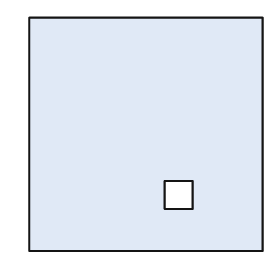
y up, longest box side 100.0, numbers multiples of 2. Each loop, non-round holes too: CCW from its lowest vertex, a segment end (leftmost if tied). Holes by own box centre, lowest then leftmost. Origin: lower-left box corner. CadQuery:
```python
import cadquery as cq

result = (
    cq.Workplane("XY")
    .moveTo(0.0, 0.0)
    .lineTo(100.0, 0.0)
    .lineTo(100.0, 100.0)
    .lineTo(0.0, 100.0)
    .close()
    .moveTo(58.0, 18.0)
    .lineTo(70.0, 18.0)
    .lineTo(70.0, 30.0)
    .lineTo(58.0, 30.0)
    .close()
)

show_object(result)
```